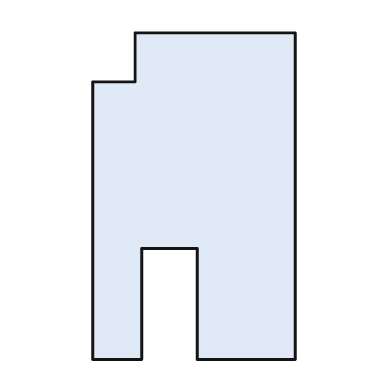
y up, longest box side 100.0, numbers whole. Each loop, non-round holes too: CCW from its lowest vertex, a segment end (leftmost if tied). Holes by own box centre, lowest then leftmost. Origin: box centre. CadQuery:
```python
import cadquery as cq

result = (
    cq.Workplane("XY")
    .moveTo(-31.0, -50.0)
    .lineTo(-16.0, -50.0)
    .lineTo(-16.0, -16.0)
    .lineTo(1.0, -16.0)
    .lineTo(1.0, -50.0)
    .lineTo(31.0, -50.0)
    .lineTo(31.0, 50.0)
    .lineTo(-18.0, 50.0)
    .lineTo(-18.0, 35.0)
    .lineTo(-31.0, 35.0)
    .close()
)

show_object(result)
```